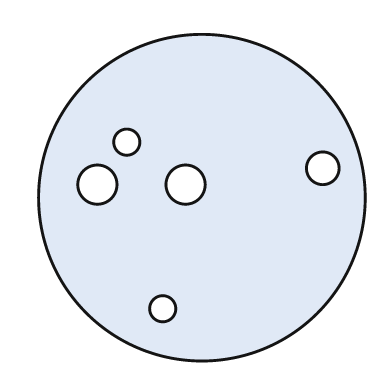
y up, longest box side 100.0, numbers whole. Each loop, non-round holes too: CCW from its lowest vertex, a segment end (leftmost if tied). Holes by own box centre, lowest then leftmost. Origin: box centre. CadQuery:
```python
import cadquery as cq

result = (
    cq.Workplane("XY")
    .moveTo(0.0, 0.0)
    .circle(50.0)
    .moveTo(-12.0, -34.0)
    .circle(4.0)
    .moveTo(-32.0, 4.0)
    .circle(6.0)
    .moveTo(-5.0, 4.0)
    .circle(6.0)
    .moveTo(37.0, 9.0)
    .circle(5.0)
    .moveTo(-23.0, 17.0)
    .circle(4.0)
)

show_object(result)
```